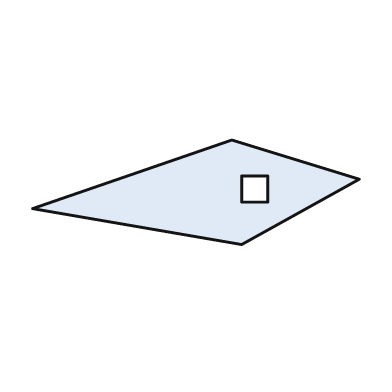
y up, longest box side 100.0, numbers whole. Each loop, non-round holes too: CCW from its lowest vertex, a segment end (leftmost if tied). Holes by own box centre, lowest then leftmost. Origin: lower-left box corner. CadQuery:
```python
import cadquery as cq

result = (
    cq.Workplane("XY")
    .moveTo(64.0, 0.0)
    .lineTo(100.0, 20.0)
    .lineTo(61.0, 32.0)
    .lineTo(0.0, 11.0)
    .close()
    .moveTo(64.0, 13.0)
    .lineTo(72.0, 13.0)
    .lineTo(72.0, 21.0)
    .lineTo(64.0, 21.0)
    .close()
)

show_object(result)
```